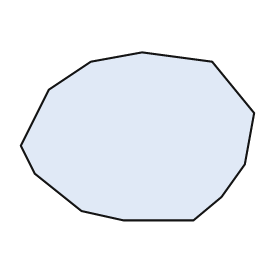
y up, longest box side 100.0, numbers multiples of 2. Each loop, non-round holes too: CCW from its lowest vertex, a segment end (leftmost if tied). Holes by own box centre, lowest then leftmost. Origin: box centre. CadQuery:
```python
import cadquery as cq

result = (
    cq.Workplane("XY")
    .moveTo(-6.0, -36.0)
    .lineTo(24.0, -36.0)
    .lineTo(36.0, -26.0)
    .lineTo(46.0, -12.0)
    .lineTo(50.0, 10.0)
    .lineTo(32.0, 32.0)
    .lineTo(2.0, 36.0)
    .lineTo(-20.0, 32.0)
    .lineTo(-38.0, 20.0)
    .lineTo(-50.0, -4.0)
    .lineTo(-44.0, -16.0)
    .lineTo(-24.0, -32.0)
    .close()
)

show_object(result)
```